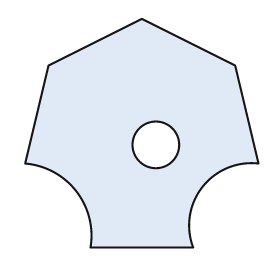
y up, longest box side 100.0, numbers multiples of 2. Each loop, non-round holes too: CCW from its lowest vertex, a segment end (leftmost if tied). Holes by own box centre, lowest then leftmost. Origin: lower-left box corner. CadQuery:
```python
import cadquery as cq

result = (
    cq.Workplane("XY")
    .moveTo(28.0, 0.0)
    .lineTo(72.0, 0.0)
    .threePointArc((76.0, 26.0), (100.0, 36.0))
    .lineTo(90.0, 78.0)
    .lineTo(50.0, 98.0)
    .lineTo(10.0, 78.0)
    .lineTo(0.0, 36.0)
    .threePointArc((22.0, 24.0), (28.0, 0.0))
    .close()
    .moveTo(56.0, 44.0)
    .circle(10.0)
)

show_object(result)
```